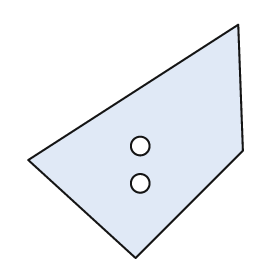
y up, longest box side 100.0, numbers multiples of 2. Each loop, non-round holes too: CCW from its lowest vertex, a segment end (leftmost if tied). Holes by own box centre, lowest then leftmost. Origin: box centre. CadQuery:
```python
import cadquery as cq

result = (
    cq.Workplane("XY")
    .moveTo(0.0, -50.0)
    .lineTo(46.0, -4.0)
    .lineTo(44.0, 50.0)
    .lineTo(-46.0, -8.0)
    .close()
    .moveTo(2.0, -18.0)
    .circle(4.0)
    .moveTo(2.0, -2.0)
    .circle(4.0)
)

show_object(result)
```